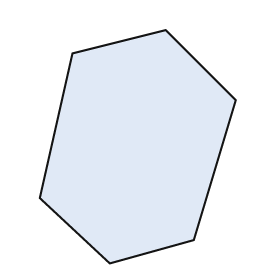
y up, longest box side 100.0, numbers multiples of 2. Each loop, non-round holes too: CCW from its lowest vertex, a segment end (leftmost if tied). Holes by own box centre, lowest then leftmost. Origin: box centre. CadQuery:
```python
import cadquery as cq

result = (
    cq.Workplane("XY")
    .moveTo(-12.0, -50.0)
    .lineTo(24.0, -40.0)
    .lineTo(42.0, 20.0)
    .lineTo(12.0, 50.0)
    .lineTo(-28.0, 40.0)
    .lineTo(-42.0, -22.0)
    .close()
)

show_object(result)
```